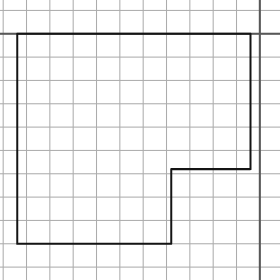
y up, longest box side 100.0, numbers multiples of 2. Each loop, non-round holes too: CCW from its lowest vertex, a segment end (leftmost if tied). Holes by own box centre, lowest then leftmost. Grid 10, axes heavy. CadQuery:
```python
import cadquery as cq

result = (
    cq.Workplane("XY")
    .moveTo(-104.0, -90.0)
    .lineTo(-38.0, -90.0)
    .lineTo(-38.0, -58.0)
    .lineTo(-4.0, -58.0)
    .lineTo(-4.0, 0.0)
    .lineTo(-104.0, 0.0)
    .close()
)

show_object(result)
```